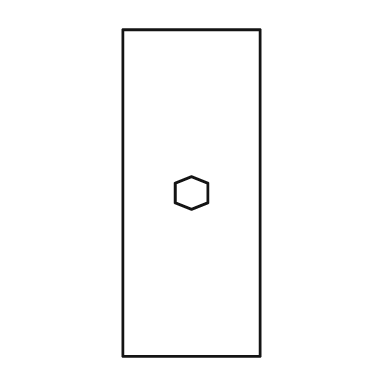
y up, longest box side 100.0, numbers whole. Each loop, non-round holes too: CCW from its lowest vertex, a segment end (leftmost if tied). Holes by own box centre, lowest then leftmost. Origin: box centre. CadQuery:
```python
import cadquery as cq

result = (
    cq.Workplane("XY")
    .moveTo(-21.0, -50.0)
    .lineTo(21.0, -50.0)
    .lineTo(21.0, 50.0)
    .lineTo(-21.0, 50.0)
    .close()
    .moveTo(0.0, -5.0)
    .lineTo(5.0, -3.0)
    .lineTo(5.0, 3.0)
    .lineTo(0.0, 5.0)
    .lineTo(-5.0, 3.0)
    .lineTo(-5.0, -3.0)
    .close()
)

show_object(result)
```